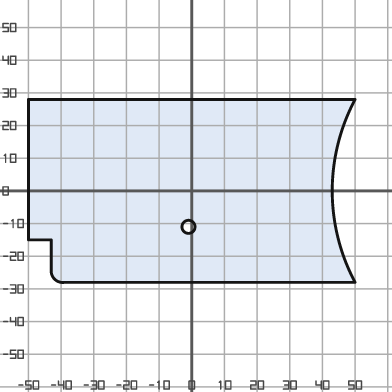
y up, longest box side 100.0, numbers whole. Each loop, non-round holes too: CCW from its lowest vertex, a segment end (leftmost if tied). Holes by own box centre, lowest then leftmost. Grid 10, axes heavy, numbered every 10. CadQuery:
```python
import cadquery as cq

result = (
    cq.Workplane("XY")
    .moveTo(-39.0, -28.0)
    .lineTo(50.0, -28.0)
    .threePointArc((43.0, 0.0), (50.0, 28.0))
    .lineTo(-50.0, 28.0)
    .lineTo(-50.0, -15.0)
    .lineTo(-43.0, -15.0)
    .lineTo(-43.0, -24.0)
    .threePointArc((-42.0, -27.0), (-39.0, -28.0))
    .close()
    .moveTo(-1.0, -11.0)
    .circle(2.0)
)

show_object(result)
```